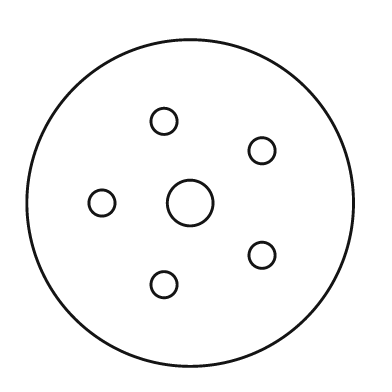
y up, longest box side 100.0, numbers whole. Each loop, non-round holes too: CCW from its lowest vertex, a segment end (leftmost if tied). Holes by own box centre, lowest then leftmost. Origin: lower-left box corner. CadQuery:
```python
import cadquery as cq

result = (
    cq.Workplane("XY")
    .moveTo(50.0, 50.0)
    .circle(50.0)
    .moveTo(42.0, 25.0)
    .circle(4.0)
    .moveTo(72.0, 34.0)
    .circle(4.0)
    .moveTo(23.0, 50.0)
    .circle(4.0)
    .moveTo(50.0, 50.0)
    .circle(7.0)
    .moveTo(72.0, 66.0)
    .circle(4.0)
    .moveTo(42.0, 75.0)
    .circle(4.0)
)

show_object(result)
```